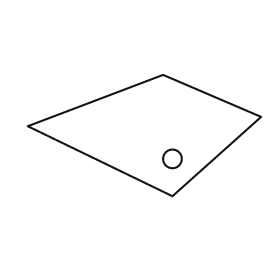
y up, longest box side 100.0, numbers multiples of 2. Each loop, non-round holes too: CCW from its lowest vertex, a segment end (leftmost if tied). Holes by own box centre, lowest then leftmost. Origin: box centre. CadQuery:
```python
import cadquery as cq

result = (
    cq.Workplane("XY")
    .moveTo(12.0, -26.0)
    .lineTo(50.0, 8.0)
    .lineTo(8.0, 26.0)
    .lineTo(-50.0, 4.0)
    .close()
    .moveTo(12.0, -10.0)
    .circle(4.0)
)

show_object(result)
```